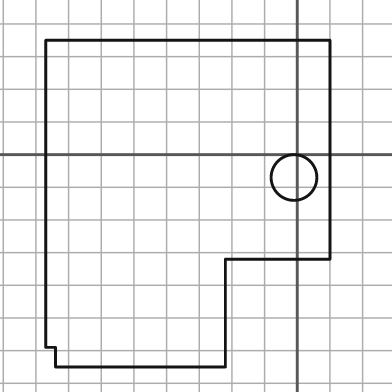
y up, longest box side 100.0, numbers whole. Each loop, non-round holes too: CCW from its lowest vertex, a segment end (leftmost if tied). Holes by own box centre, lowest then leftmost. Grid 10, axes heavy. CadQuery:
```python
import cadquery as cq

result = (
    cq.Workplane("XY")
    .moveTo(-74.0, -65.0)
    .lineTo(-22.0, -65.0)
    .lineTo(-22.0, -32.0)
    .lineTo(10.0, -32.0)
    .lineTo(10.0, 35.0)
    .lineTo(-77.0, 35.0)
    .lineTo(-77.0, -59.0)
    .lineTo(-74.0, -59.0)
    .close()
    .moveTo(-1.0, -7.0)
    .circle(7.0)
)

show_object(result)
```